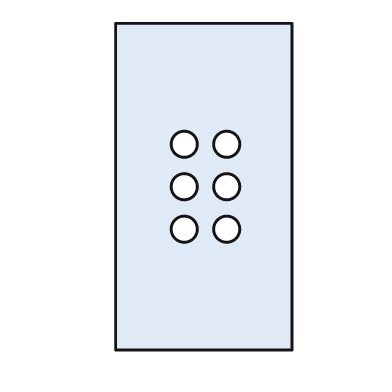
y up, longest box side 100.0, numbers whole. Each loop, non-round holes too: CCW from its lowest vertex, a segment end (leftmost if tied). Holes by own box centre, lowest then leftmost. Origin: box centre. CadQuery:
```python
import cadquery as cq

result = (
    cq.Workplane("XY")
    .moveTo(-27.0, -50.0)
    .lineTo(27.0, -50.0)
    .lineTo(27.0, 50.0)
    .lineTo(-27.0, 50.0)
    .close()
    .moveTo(-6.0, -13.0)
    .circle(4.0)
    .moveTo(7.0, -13.0)
    .circle(4.0)
    .moveTo(-6.0, 0.0)
    .circle(4.0)
    .moveTo(7.0, 0.0)
    .circle(4.0)
    .moveTo(-6.0, 13.0)
    .circle(4.0)
    .moveTo(7.0, 13.0)
    .circle(4.0)
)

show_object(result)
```